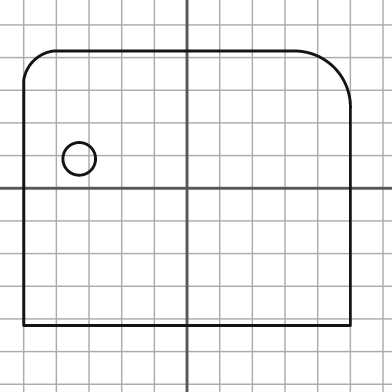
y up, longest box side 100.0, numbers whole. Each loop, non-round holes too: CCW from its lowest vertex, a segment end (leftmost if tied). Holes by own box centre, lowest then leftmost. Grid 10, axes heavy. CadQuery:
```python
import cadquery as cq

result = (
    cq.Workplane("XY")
    .moveTo(-50.0, -42.0)
    .lineTo(50.0, -42.0)
    .lineTo(50.0, 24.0)
    .threePointArc((45.0, 37.0), (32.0, 42.0))
    .lineTo(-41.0, 42.0)
    .threePointArc((-47.0, 39.0), (-50.0, 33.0))
    .close()
    .moveTo(-33.0, 9.0)
    .circle(5.0)
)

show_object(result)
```